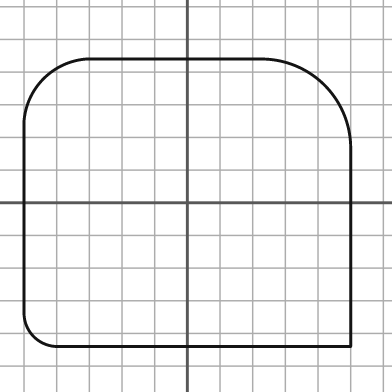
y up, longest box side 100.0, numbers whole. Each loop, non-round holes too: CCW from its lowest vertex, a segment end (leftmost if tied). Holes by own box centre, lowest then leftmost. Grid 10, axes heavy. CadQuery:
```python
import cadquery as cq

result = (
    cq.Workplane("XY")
    .moveTo(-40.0, -44.0)
    .lineTo(50.0, -44.0)
    .lineTo(50.0, 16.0)
    .threePointArc((42.0, 36.0), (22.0, 44.0))
    .lineTo(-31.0, 44.0)
    .threePointArc((-44.0, 38.0), (-50.0, 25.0))
    .lineTo(-50.0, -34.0)
    .threePointArc((-47.0, -41.0), (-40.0, -44.0))
    .close()
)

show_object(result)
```